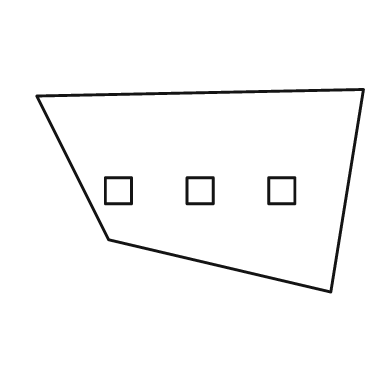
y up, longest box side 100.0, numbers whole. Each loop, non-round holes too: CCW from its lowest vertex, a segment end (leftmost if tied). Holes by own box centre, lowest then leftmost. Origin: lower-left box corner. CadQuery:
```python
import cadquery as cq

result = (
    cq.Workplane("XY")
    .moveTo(90.0, 0.0)
    .lineTo(100.0, 62.0)
    .lineTo(0.0, 60.0)
    .lineTo(22.0, 16.0)
    .close()
    .moveTo(21.0, 27.0)
    .lineTo(29.0, 27.0)
    .lineTo(29.0, 35.0)
    .lineTo(21.0, 35.0)
    .close()
    .moveTo(46.0, 27.0)
    .lineTo(54.0, 27.0)
    .lineTo(54.0, 35.0)
    .lineTo(46.0, 35.0)
    .close()
    .moveTo(71.0, 27.0)
    .lineTo(79.0, 27.0)
    .lineTo(79.0, 35.0)
    .lineTo(71.0, 35.0)
    .close()
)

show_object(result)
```